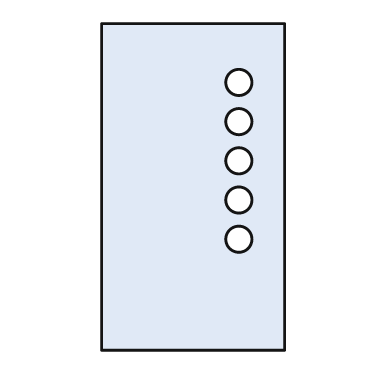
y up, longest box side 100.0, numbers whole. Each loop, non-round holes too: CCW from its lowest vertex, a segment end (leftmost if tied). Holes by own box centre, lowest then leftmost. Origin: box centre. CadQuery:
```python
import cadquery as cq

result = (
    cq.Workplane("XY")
    .moveTo(-28.0, -50.0)
    .lineTo(28.0, -50.0)
    .lineTo(28.0, 50.0)
    .lineTo(-28.0, 50.0)
    .close()
    .moveTo(14.0, -16.0)
    .circle(4.0)
    .moveTo(14.0, -4.0)
    .circle(4.0)
    .moveTo(14.0, 8.0)
    .circle(4.0)
    .moveTo(14.0, 20.0)
    .circle(4.0)
    .moveTo(14.0, 32.0)
    .circle(4.0)
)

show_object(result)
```